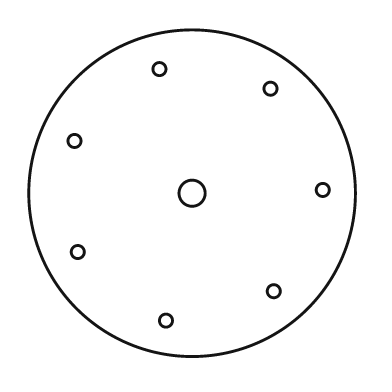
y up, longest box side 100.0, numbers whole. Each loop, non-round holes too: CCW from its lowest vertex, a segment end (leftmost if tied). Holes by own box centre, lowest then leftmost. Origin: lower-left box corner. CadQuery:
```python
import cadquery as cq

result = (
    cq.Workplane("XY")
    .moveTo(50.0, 50.0)
    .circle(50.0)
    .moveTo(42.0, 11.0)
    .circle(2.0)
    .moveTo(75.0, 20.0)
    .circle(2.0)
    .moveTo(15.0, 32.0)
    .circle(2.0)
    .moveTo(50.0, 50.0)
    .circle(4.0)
    .moveTo(90.0, 51.0)
    .circle(2.0)
    .moveTo(14.0, 66.0)
    .circle(2.0)
    .moveTo(74.0, 82.0)
    .circle(2.0)
    .moveTo(40.0, 88.0)
    .circle(2.0)
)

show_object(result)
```